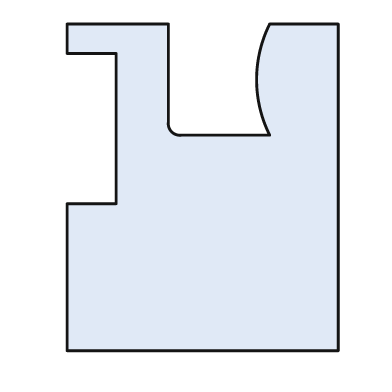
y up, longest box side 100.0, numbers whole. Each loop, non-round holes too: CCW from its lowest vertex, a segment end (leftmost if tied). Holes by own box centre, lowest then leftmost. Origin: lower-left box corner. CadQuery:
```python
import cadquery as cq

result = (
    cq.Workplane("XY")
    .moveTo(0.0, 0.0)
    .lineTo(83.0, 0.0)
    .lineTo(83.0, 100.0)
    .lineTo(62.0, 100.0)
    .threePointArc((58.0, 83.0), (62.0, 66.0))
    .lineTo(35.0, 66.0)
    .threePointArc((32.0, 67.0), (31.0, 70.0))
    .lineTo(31.0, 100.0)
    .lineTo(0.0, 100.0)
    .lineTo(0.0, 91.0)
    .lineTo(15.0, 91.0)
    .lineTo(15.0, 45.0)
    .lineTo(0.0, 45.0)
    .close()
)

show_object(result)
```